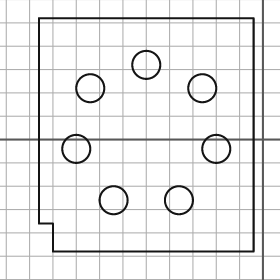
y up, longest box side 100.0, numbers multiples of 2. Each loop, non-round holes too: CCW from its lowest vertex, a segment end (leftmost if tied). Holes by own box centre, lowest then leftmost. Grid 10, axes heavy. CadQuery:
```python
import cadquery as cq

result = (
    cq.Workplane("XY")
    .moveTo(-90.0, -48.0)
    .lineTo(-4.0, -48.0)
    .lineTo(-4.0, 52.0)
    .lineTo(-96.0, 52.0)
    .lineTo(-96.0, -36.0)
    .lineTo(-90.0, -36.0)
    .close()
    .moveTo(-64.0, -26.0)
    .circle(6.0)
    .moveTo(-36.0, -26.0)
    .circle(6.0)
    .moveTo(-80.0, -4.0)
    .circle(6.0)
    .moveTo(-20.0, -4.0)
    .circle(6.0)
    .moveTo(-74.0, 22.0)
    .circle(6.0)
    .moveTo(-26.0, 22.0)
    .circle(6.0)
    .moveTo(-50.0, 32.0)
    .circle(6.0)
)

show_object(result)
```